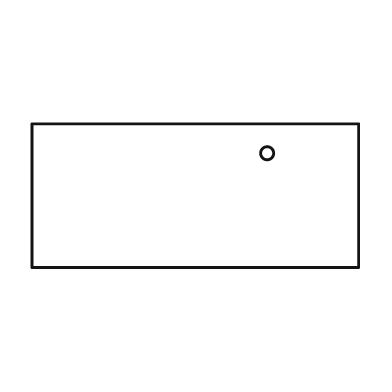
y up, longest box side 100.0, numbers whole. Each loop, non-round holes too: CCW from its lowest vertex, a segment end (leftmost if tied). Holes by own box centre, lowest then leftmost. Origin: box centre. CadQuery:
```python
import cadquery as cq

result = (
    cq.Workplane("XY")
    .moveTo(-50.0, -22.0)
    .lineTo(50.0, -22.0)
    .lineTo(50.0, 22.0)
    .lineTo(-50.0, 22.0)
    .close()
    .moveTo(22.0, 13.0)
    .circle(2.0)
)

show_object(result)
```